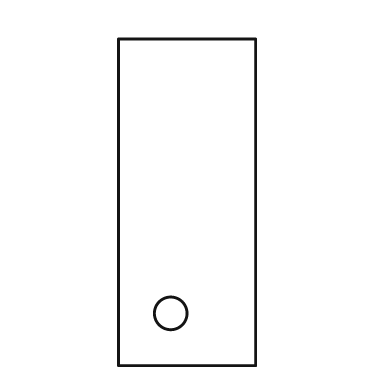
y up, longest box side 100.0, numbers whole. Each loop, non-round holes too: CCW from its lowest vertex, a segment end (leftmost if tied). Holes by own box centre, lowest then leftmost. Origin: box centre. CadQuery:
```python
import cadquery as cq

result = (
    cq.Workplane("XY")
    .moveTo(-21.0, -50.0)
    .lineTo(21.0, -50.0)
    .lineTo(21.0, 50.0)
    .lineTo(-21.0, 50.0)
    .close()
    .moveTo(-5.0, -34.0)
    .circle(5.0)
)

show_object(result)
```